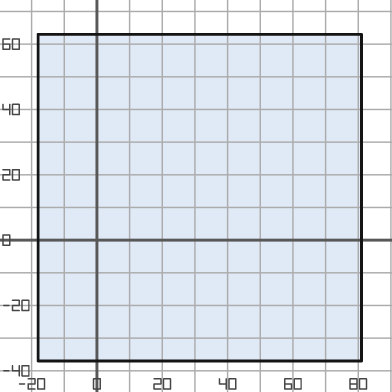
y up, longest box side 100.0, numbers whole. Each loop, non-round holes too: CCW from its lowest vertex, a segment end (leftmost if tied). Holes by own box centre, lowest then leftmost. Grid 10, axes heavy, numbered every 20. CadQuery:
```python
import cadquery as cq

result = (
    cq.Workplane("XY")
    .moveTo(-18.0, -37.0)
    .lineTo(81.0, -37.0)
    .lineTo(81.0, 63.0)
    .lineTo(-18.0, 63.0)
    .close()
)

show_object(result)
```